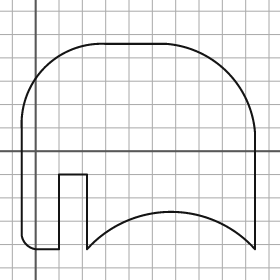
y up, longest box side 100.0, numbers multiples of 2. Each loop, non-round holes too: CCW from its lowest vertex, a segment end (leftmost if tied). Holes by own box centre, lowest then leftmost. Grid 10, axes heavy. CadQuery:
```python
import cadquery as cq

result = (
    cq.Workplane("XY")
    .moveTo(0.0, -42.0)
    .lineTo(10.0, -42.0)
    .lineTo(10.0, -10.0)
    .lineTo(22.0, -10.0)
    .lineTo(22.0, -42.0)
    .threePointArc((58.0, -26.0), (94.0, -42.0))
    .lineTo(94.0, 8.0)
    .threePointArc((82.0, 34.0), (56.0, 46.0))
    .lineTo(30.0, 46.0)
    .threePointArc((4.0, 36.0), (-6.0, 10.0))
    .lineTo(-6.0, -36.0)
    .threePointArc((-4.0, -40.0), (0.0, -42.0))
    .close()
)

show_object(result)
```